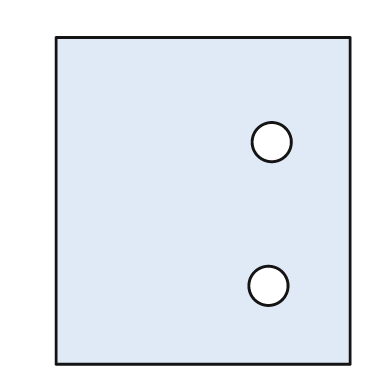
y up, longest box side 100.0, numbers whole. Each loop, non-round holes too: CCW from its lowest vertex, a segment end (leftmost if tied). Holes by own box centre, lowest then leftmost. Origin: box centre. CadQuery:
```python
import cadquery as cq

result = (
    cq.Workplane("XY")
    .moveTo(-45.0, -50.0)
    .lineTo(45.0, -50.0)
    .lineTo(45.0, 50.0)
    .lineTo(-45.0, 50.0)
    .close()
    .moveTo(20.0, -26.0)
    .circle(6.0)
    .moveTo(21.0, 18.0)
    .circle(6.0)
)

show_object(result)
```